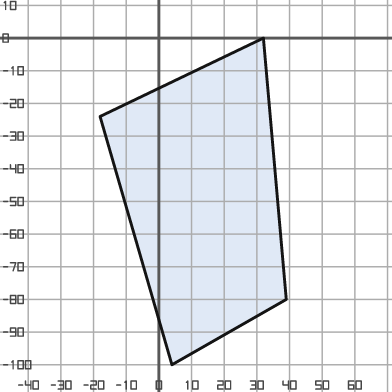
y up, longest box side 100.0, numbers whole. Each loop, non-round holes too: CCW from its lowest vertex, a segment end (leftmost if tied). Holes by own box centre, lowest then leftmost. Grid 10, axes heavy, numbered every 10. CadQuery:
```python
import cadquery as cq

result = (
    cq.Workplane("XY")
    .moveTo(4.0, -100.0)
    .lineTo(39.0, -80.0)
    .lineTo(32.0, 0.0)
    .lineTo(-18.0, -24.0)
    .close()
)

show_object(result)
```